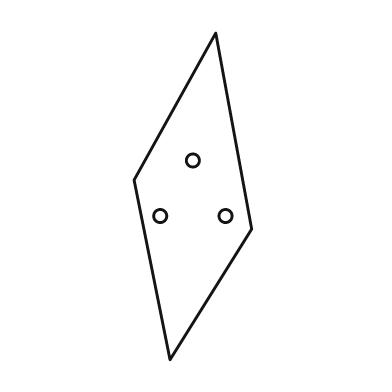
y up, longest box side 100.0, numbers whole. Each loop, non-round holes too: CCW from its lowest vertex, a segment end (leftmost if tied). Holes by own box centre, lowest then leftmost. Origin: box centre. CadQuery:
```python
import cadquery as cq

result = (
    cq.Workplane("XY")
    .moveTo(-7.0, -50.0)
    .lineTo(18.0, -10.0)
    .lineTo(7.0, 50.0)
    .lineTo(-18.0, 5.0)
    .close()
    .moveTo(-10.0, -6.0)
    .circle(2.0)
    .moveTo(10.0, -6.0)
    .circle(2.0)
    .moveTo(0.0, 11.0)
    .circle(2.0)
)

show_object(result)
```